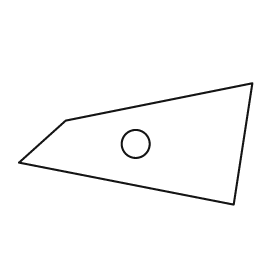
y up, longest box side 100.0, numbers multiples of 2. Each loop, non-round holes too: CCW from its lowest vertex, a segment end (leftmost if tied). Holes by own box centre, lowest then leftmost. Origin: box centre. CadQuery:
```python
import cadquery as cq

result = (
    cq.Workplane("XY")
    .moveTo(42.0, -26.0)
    .lineTo(50.0, 26.0)
    .lineTo(-30.0, 10.0)
    .lineTo(-50.0, -8.0)
    .close()
    .moveTo(0.0, 0.0)
    .circle(6.0)
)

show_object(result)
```